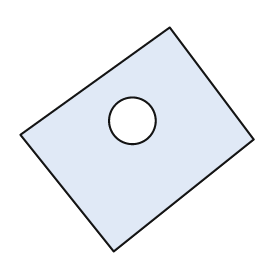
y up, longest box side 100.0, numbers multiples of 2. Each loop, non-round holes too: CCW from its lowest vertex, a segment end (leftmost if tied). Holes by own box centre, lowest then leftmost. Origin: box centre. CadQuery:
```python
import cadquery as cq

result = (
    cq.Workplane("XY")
    .moveTo(-10.0, -48.0)
    .lineTo(50.0, 0.0)
    .lineTo(14.0, 48.0)
    .lineTo(-50.0, 2.0)
    .close()
    .moveTo(-2.0, 8.0)
    .circle(10.0)
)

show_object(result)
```